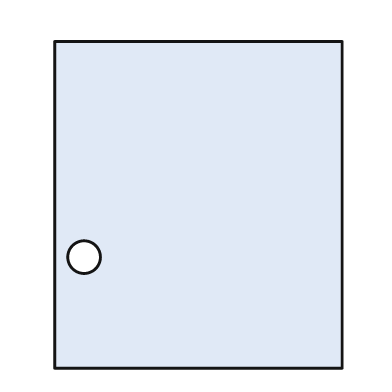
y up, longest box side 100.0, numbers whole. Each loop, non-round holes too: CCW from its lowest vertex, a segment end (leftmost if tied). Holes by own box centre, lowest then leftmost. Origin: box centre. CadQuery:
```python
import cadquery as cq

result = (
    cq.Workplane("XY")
    .moveTo(-44.0, -50.0)
    .lineTo(44.0, -50.0)
    .lineTo(44.0, 50.0)
    .lineTo(-44.0, 50.0)
    .close()
    .moveTo(-35.0, -16.0)
    .circle(5.0)
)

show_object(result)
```